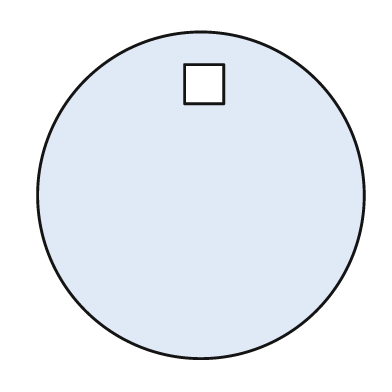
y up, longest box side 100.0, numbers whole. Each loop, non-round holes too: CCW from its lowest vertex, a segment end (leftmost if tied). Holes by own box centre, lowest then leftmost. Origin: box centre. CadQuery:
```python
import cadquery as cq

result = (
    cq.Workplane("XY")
    .moveTo(0.0, 0.0)
    .circle(50.0)
    .moveTo(-5.0, 28.0)
    .lineTo(7.0, 28.0)
    .lineTo(7.0, 40.0)
    .lineTo(-5.0, 40.0)
    .close()
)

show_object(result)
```